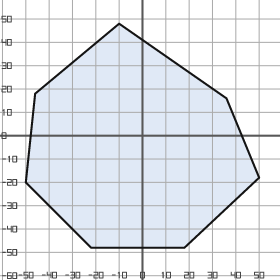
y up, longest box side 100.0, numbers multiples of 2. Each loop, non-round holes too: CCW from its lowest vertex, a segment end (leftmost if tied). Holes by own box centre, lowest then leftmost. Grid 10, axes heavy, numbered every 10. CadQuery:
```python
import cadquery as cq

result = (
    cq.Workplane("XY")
    .moveTo(-22.0, -48.0)
    .lineTo(18.0, -48.0)
    .lineTo(50.0, -18.0)
    .lineTo(36.0, 16.0)
    .lineTo(-10.0, 48.0)
    .lineTo(-46.0, 18.0)
    .lineTo(-50.0, -20.0)
    .close()
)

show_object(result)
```